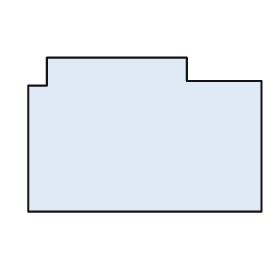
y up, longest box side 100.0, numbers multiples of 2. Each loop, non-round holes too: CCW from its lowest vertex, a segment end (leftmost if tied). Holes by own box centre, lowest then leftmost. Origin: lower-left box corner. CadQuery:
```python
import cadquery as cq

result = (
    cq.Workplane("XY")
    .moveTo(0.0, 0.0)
    .lineTo(100.0, 0.0)
    .lineTo(100.0, 56.0)
    .lineTo(68.0, 56.0)
    .lineTo(68.0, 66.0)
    .lineTo(8.0, 66.0)
    .lineTo(8.0, 54.0)
    .lineTo(0.0, 54.0)
    .close()
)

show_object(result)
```